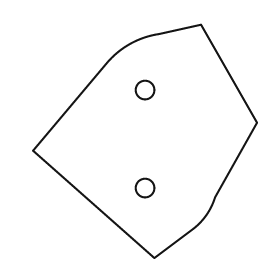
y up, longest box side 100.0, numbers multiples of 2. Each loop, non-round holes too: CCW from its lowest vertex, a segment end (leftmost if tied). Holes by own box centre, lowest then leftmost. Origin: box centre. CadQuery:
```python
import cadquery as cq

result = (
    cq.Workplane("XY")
    .moveTo(4.0, -50.0)
    .lineTo(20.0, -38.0)
    .threePointArc((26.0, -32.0), (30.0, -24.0))
    .lineTo(48.0, 8.0)
    .lineTo(24.0, 50.0)
    .lineTo(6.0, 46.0)
    .threePointArc((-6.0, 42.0), (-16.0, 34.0))
    .lineTo(-48.0, -4.0)
    .close()
    .moveTo(0.0, -20.0)
    .circle(4.0)
    .moveTo(0.0, 22.0)
    .circle(4.0)
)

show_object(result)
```